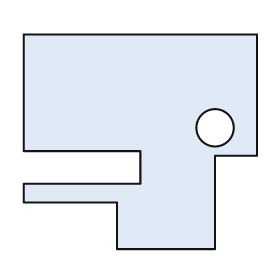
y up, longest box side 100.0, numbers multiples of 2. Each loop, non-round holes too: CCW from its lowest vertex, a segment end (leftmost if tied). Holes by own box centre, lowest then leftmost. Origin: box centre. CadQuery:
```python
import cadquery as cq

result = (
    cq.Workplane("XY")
    .moveTo(-10.0, -46.0)
    .lineTo(32.0, -46.0)
    .lineTo(32.0, -6.0)
    .lineTo(50.0, -6.0)
    .lineTo(50.0, 46.0)
    .lineTo(-50.0, 46.0)
    .lineTo(-50.0, -4.0)
    .lineTo(0.0, -4.0)
    .lineTo(0.0, -18.0)
    .lineTo(-50.0, -18.0)
    .lineTo(-50.0, -26.0)
    .lineTo(-10.0, -26.0)
    .close()
    .moveTo(32.0, 6.0)
    .circle(8.0)
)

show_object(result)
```